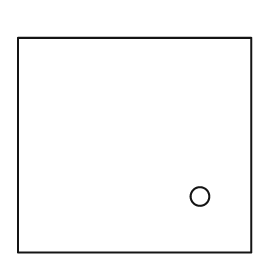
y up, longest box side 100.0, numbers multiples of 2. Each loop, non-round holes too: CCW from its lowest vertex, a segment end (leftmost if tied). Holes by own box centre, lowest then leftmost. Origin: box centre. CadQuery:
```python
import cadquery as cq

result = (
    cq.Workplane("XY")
    .moveTo(-50.0, -46.0)
    .lineTo(50.0, -46.0)
    .lineTo(50.0, 46.0)
    .lineTo(-50.0, 46.0)
    .close()
    .moveTo(28.0, -22.0)
    .circle(4.0)
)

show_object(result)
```